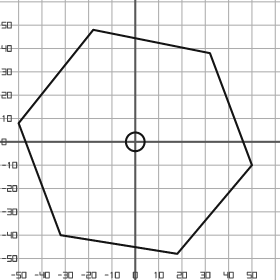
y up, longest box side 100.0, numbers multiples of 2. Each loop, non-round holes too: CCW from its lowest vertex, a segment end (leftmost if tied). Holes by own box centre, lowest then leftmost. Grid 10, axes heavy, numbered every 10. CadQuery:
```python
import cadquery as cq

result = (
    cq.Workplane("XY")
    .moveTo(18.0, -48.0)
    .lineTo(50.0, -10.0)
    .lineTo(32.0, 38.0)
    .lineTo(-18.0, 48.0)
    .lineTo(-50.0, 8.0)
    .lineTo(-32.0, -40.0)
    .close()
    .moveTo(0.0, 0.0)
    .circle(4.0)
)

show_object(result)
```